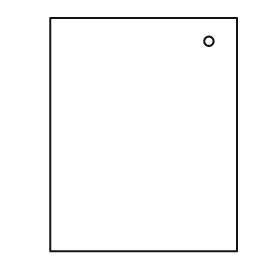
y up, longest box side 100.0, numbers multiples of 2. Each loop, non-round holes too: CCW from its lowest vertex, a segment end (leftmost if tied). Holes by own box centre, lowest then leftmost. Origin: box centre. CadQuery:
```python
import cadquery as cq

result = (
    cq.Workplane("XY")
    .moveTo(-40.0, -50.0)
    .lineTo(40.0, -50.0)
    .lineTo(40.0, 50.0)
    .lineTo(-40.0, 50.0)
    .close()
    .moveTo(28.0, 40.0)
    .circle(2.0)
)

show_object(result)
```